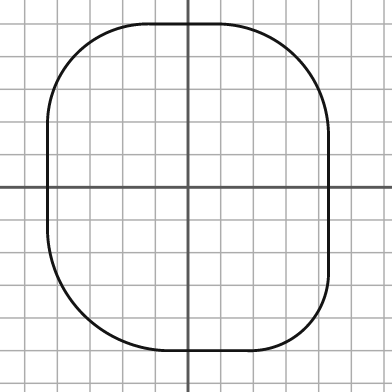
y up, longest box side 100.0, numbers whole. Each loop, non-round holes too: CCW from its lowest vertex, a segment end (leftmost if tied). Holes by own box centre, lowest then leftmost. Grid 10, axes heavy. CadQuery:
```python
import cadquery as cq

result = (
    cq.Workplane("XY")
    .moveTo(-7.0, -50.0)
    .lineTo(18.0, -50.0)
    .threePointArc((36.0, -43.0), (43.0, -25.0))
    .lineTo(43.0, 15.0)
    .threePointArc((33.0, 40.0), (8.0, 50.0))
    .lineTo(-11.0, 50.0)
    .threePointArc((-34.0, 41.0), (-43.0, 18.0))
    .lineTo(-43.0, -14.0)
    .threePointArc((-32.0, -39.0), (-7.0, -50.0))
    .close()
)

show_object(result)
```